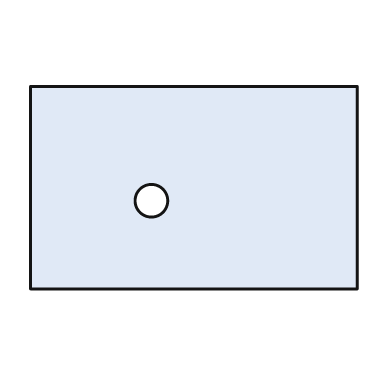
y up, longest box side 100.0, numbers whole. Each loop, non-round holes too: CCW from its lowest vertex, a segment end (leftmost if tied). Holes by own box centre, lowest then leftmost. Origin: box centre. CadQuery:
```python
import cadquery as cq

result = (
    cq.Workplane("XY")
    .moveTo(-50.0, -31.0)
    .lineTo(50.0, -31.0)
    .lineTo(50.0, 31.0)
    .lineTo(-50.0, 31.0)
    .close()
    .moveTo(-13.0, -4.0)
    .circle(5.0)
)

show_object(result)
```